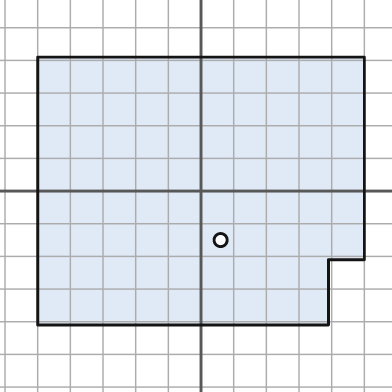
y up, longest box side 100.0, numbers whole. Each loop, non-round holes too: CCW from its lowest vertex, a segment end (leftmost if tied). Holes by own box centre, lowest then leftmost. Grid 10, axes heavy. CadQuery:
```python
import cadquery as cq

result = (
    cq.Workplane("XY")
    .moveTo(-50.0, -41.0)
    .lineTo(39.0, -41.0)
    .lineTo(39.0, -21.0)
    .lineTo(50.0, -21.0)
    .lineTo(50.0, 41.0)
    .lineTo(-50.0, 41.0)
    .close()
    .moveTo(6.0, -15.0)
    .circle(2.0)
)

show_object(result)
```